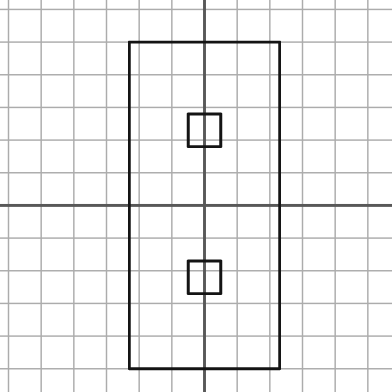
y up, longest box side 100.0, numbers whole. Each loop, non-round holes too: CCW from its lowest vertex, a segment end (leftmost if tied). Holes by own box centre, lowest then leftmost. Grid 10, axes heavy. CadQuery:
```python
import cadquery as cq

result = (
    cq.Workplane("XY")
    .moveTo(-23.0, -50.0)
    .lineTo(23.0, -50.0)
    .lineTo(23.0, 50.0)
    .lineTo(-23.0, 50.0)
    .close()
    .moveTo(-5.0, -27.0)
    .lineTo(5.0, -27.0)
    .lineTo(5.0, -17.0)
    .lineTo(-5.0, -17.0)
    .close()
    .moveTo(-5.0, 18.0)
    .lineTo(5.0, 18.0)
    .lineTo(5.0, 28.0)
    .lineTo(-5.0, 28.0)
    .close()
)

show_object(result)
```